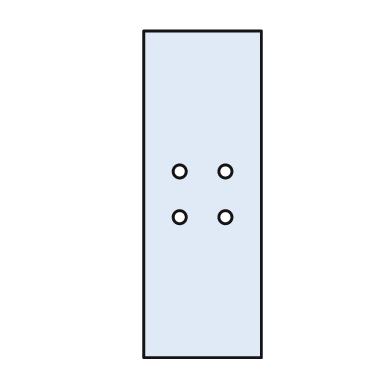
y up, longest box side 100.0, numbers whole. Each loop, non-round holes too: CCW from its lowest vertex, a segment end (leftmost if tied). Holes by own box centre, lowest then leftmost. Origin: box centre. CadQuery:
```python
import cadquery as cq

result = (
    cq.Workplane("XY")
    .moveTo(-18.0, -50.0)
    .lineTo(18.0, -50.0)
    .lineTo(18.0, 50.0)
    .lineTo(-18.0, 50.0)
    .close()
    .moveTo(-7.0, -7.0)
    .circle(2.0)
    .moveTo(7.0, -7.0)
    .circle(2.0)
    .moveTo(-7.0, 7.0)
    .circle(2.0)
    .moveTo(7.0, 7.0)
    .circle(2.0)
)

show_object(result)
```